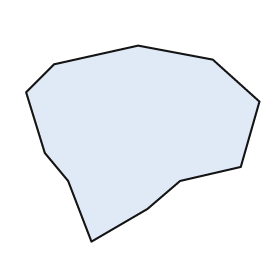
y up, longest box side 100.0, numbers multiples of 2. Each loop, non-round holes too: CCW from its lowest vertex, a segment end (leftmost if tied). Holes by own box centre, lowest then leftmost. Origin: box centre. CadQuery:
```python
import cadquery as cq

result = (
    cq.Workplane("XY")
    .moveTo(-22.0, -42.0)
    .lineTo(2.0, -28.0)
    .lineTo(16.0, -16.0)
    .lineTo(42.0, -10.0)
    .lineTo(50.0, 18.0)
    .lineTo(30.0, 36.0)
    .lineTo(-2.0, 42.0)
    .lineTo(-38.0, 34.0)
    .lineTo(-50.0, 22.0)
    .lineTo(-42.0, -4.0)
    .lineTo(-32.0, -16.0)
    .close()
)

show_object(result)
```